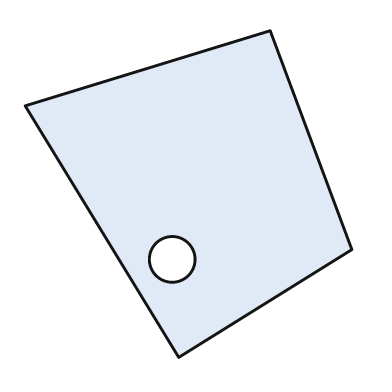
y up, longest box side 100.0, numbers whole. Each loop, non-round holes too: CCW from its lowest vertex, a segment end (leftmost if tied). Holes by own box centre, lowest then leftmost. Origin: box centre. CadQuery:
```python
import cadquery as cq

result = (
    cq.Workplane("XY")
    .moveTo(-3.0, -50.0)
    .lineTo(50.0, -17.0)
    .lineTo(25.0, 50.0)
    .lineTo(-50.0, 27.0)
    .close()
    .moveTo(-5.0, -20.0)
    .circle(7.0)
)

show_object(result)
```